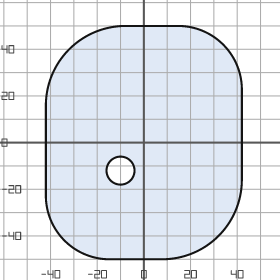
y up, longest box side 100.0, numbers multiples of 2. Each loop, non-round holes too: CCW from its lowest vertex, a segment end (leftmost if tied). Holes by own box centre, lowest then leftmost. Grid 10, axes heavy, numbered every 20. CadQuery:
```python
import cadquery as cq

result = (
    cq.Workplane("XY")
    .moveTo(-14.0, -50.0)
    .lineTo(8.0, -50.0)
    .threePointArc((32.0, -40.0), (42.0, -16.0))
    .lineTo(42.0, 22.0)
    .threePointArc((34.0, 42.0), (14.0, 50.0))
    .lineTo(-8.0, 50.0)
    .threePointArc((-32.0, 40.0), (-42.0, 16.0))
    .lineTo(-42.0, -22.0)
    .threePointArc((-34.0, -42.0), (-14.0, -50.0))
    .close()
    .moveTo(-10.0, -12.0)
    .circle(6.0)
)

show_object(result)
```